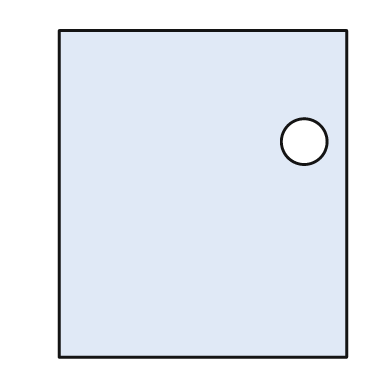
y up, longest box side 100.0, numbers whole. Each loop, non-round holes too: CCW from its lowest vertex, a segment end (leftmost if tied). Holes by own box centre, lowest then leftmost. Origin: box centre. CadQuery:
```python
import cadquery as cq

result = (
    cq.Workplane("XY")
    .moveTo(-44.0, -50.0)
    .lineTo(44.0, -50.0)
    .lineTo(44.0, 50.0)
    .lineTo(-44.0, 50.0)
    .close()
    .moveTo(31.0, 16.0)
    .circle(7.0)
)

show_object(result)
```